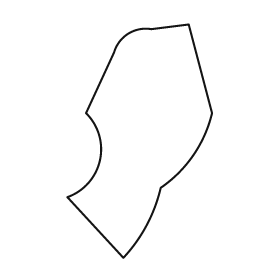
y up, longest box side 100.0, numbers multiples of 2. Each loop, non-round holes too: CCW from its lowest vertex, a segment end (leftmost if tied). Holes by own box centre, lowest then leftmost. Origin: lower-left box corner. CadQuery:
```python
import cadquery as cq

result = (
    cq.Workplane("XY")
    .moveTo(24.0, 0.0)
    .threePointArc((34.0, 14.0), (40.0, 30.0))
    .threePointArc((54.0, 44.0), (62.0, 62.0))
    .lineTo(52.0, 100.0)
    .lineTo(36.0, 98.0)
    .threePointArc((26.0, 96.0), (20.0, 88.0))
    .lineTo(8.0, 62.0)
    .threePointArc((14.0, 42.0), (0.0, 26.0))
    .close()
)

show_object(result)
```